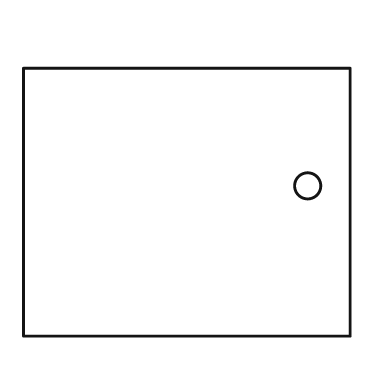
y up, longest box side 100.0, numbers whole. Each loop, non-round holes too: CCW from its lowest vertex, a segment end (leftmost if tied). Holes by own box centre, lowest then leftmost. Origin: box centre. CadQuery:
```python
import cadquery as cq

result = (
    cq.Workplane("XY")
    .moveTo(-50.0, -41.0)
    .lineTo(50.0, -41.0)
    .lineTo(50.0, 41.0)
    .lineTo(-50.0, 41.0)
    .close()
    .moveTo(37.0, 5.0)
    .circle(4.0)
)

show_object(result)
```